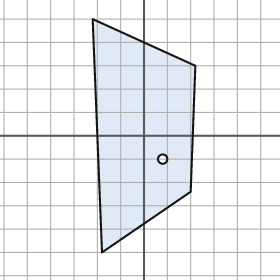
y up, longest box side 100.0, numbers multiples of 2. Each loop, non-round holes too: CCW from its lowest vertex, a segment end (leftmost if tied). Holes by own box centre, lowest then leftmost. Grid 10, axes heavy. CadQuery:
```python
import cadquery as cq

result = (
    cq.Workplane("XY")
    .moveTo(-18.0, -50.0)
    .lineTo(20.0, -24.0)
    .lineTo(22.0, 30.0)
    .lineTo(-22.0, 50.0)
    .close()
    .moveTo(8.0, -10.0)
    .circle(2.0)
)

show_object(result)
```